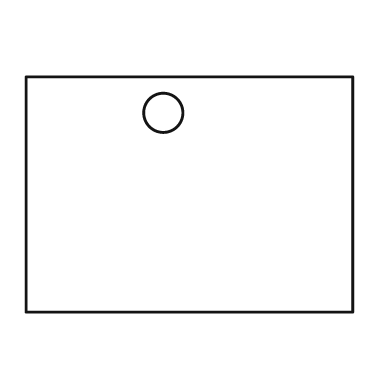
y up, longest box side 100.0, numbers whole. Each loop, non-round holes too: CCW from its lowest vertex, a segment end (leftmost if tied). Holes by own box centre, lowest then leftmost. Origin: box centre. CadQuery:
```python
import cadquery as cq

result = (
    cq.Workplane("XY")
    .moveTo(-50.0, -36.0)
    .lineTo(50.0, -36.0)
    .lineTo(50.0, 36.0)
    .lineTo(-50.0, 36.0)
    .close()
    .moveTo(-8.0, 25.0)
    .circle(6.0)
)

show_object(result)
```